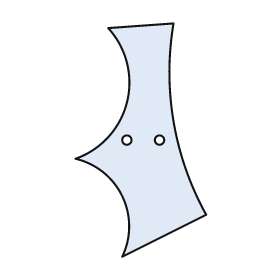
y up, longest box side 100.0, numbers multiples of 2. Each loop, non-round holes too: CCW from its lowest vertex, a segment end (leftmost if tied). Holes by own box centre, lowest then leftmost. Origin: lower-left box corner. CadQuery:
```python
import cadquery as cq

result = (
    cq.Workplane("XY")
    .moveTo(20.0, 0.0)
    .lineTo(56.0, 18.0)
    .threePointArc((42.0, 58.0), (42.0, 100.0))
    .lineTo(14.0, 98.0)
    .threePointArc((22.0, 66.0), (0.0, 42.0))
    .threePointArc((20.0, 26.0), (20.0, 0.0))
    .close()
    .moveTo(22.0, 50.0)
    .circle(2.0)
    .moveTo(36.0, 50.0)
    .circle(2.0)
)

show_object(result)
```